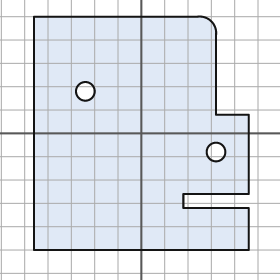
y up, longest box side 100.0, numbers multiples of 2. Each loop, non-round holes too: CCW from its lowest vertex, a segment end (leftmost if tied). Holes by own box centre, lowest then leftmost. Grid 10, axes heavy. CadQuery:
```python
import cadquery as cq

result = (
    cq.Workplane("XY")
    .moveTo(-46.0, -50.0)
    .lineTo(46.0, -50.0)
    .lineTo(46.0, -32.0)
    .lineTo(18.0, -32.0)
    .lineTo(18.0, -26.0)
    .lineTo(46.0, -26.0)
    .lineTo(46.0, 8.0)
    .lineTo(32.0, 8.0)
    .lineTo(32.0, 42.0)
    .threePointArc((30.0, 48.0), (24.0, 50.0))
    .lineTo(-46.0, 50.0)
    .close()
    .moveTo(32.0, -8.0)
    .circle(4.0)
    .moveTo(-24.0, 18.0)
    .circle(4.0)
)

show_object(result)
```